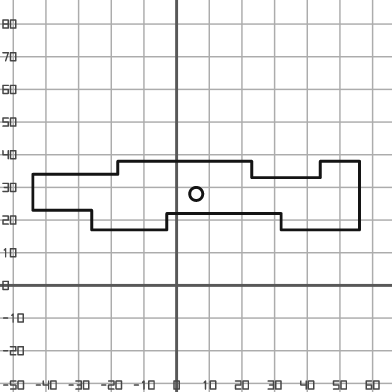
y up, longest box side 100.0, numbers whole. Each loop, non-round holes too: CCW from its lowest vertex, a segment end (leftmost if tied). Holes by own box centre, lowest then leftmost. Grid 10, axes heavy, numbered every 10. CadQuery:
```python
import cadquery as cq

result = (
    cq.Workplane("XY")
    .moveTo(-26.0, 17.0)
    .lineTo(-3.0, 17.0)
    .lineTo(-3.0, 22.0)
    .lineTo(32.0, 22.0)
    .lineTo(32.0, 17.0)
    .lineTo(56.0, 17.0)
    .lineTo(56.0, 38.0)
    .lineTo(44.0, 38.0)
    .lineTo(44.0, 33.0)
    .lineTo(23.0, 33.0)
    .lineTo(23.0, 38.0)
    .lineTo(-18.0, 38.0)
    .lineTo(-18.0, 34.0)
    .lineTo(-44.0, 34.0)
    .lineTo(-44.0, 23.0)
    .lineTo(-26.0, 23.0)
    .close()
    .moveTo(6.0, 28.0)
    .circle(2.0)
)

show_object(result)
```